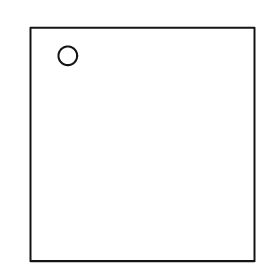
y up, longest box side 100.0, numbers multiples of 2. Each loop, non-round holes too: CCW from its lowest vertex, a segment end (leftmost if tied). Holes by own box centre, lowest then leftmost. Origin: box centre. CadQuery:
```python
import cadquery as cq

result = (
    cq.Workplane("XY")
    .moveTo(-48.0, -50.0)
    .lineTo(48.0, -50.0)
    .lineTo(48.0, 50.0)
    .lineTo(-48.0, 50.0)
    .close()
    .moveTo(-32.0, 38.0)
    .circle(4.0)
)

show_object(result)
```